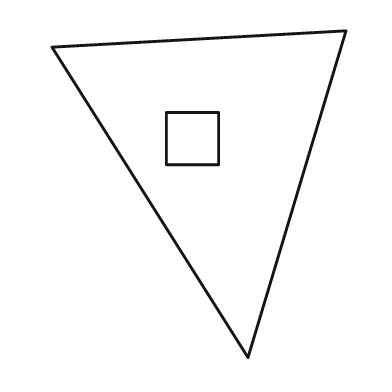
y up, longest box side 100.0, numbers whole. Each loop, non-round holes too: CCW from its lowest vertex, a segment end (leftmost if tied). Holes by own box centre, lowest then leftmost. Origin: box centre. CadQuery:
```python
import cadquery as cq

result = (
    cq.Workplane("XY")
    .moveTo(15.0, -50.0)
    .lineTo(45.0, 50.0)
    .lineTo(-45.0, 45.0)
    .close()
    .moveTo(-10.0, 9.0)
    .lineTo(6.0, 9.0)
    .lineTo(6.0, 25.0)
    .lineTo(-10.0, 25.0)
    .close()
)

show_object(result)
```